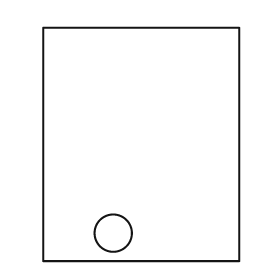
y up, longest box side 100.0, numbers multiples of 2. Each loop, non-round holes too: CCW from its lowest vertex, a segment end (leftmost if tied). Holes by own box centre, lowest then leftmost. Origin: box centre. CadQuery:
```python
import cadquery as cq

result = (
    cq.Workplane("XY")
    .moveTo(-42.0, -50.0)
    .lineTo(42.0, -50.0)
    .lineTo(42.0, 50.0)
    .lineTo(-42.0, 50.0)
    .close()
    .moveTo(-12.0, -38.0)
    .circle(8.0)
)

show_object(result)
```